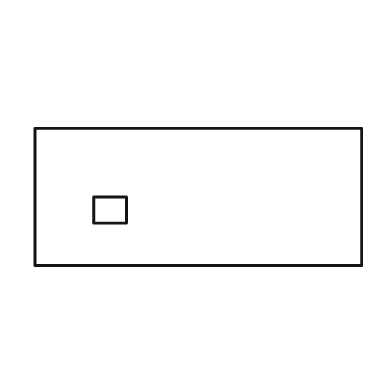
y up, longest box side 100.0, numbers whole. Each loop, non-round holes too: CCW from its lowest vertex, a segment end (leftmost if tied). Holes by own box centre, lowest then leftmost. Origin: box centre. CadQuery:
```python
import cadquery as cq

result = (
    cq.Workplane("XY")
    .moveTo(-50.0, -21.0)
    .lineTo(50.0, -21.0)
    .lineTo(50.0, 21.0)
    .lineTo(-50.0, 21.0)
    .close()
    .moveTo(-32.0, -8.0)
    .lineTo(-22.0, -8.0)
    .lineTo(-22.0, 0.0)
    .lineTo(-32.0, 0.0)
    .close()
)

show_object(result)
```